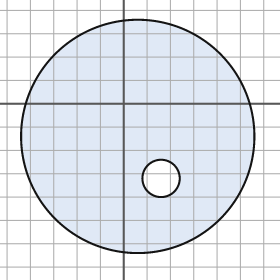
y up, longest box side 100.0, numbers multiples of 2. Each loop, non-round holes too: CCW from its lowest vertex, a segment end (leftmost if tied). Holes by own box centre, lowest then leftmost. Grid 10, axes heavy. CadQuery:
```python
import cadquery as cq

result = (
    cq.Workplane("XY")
    .moveTo(6.0, -14.0)
    .circle(50.0)
    .moveTo(16.0, -32.0)
    .circle(8.0)
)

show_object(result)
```